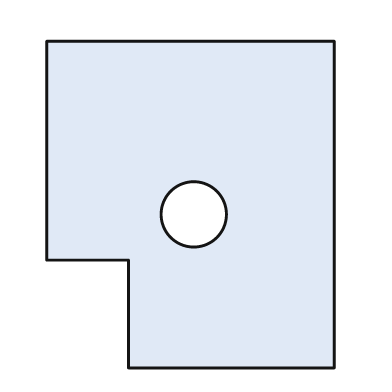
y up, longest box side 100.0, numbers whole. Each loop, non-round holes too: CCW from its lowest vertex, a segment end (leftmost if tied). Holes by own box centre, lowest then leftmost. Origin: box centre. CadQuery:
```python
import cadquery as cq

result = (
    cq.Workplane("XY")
    .moveTo(-19.0, -50.0)
    .lineTo(44.0, -50.0)
    .lineTo(44.0, 50.0)
    .lineTo(-44.0, 50.0)
    .lineTo(-44.0, -17.0)
    .lineTo(-19.0, -17.0)
    .close()
    .moveTo(1.0, -3.0)
    .circle(10.0)
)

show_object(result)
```